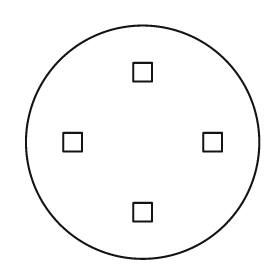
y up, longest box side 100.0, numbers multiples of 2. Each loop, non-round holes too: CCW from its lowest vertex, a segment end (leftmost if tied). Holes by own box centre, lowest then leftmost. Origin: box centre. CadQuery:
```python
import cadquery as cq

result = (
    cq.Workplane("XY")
    .moveTo(0.0, 0.0)
    .circle(50.0)
    .moveTo(-4.0, -34.0)
    .lineTo(4.0, -34.0)
    .lineTo(4.0, -26.0)
    .lineTo(-4.0, -26.0)
    .close()
    .moveTo(-34.0, -4.0)
    .lineTo(-26.0, -4.0)
    .lineTo(-26.0, 4.0)
    .lineTo(-34.0, 4.0)
    .close()
    .moveTo(26.0, -4.0)
    .lineTo(34.0, -4.0)
    .lineTo(34.0, 4.0)
    .lineTo(26.0, 4.0)
    .close()
    .moveTo(-4.0, 26.0)
    .lineTo(4.0, 26.0)
    .lineTo(4.0, 34.0)
    .lineTo(-4.0, 34.0)
    .close()
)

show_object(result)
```